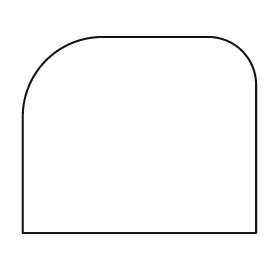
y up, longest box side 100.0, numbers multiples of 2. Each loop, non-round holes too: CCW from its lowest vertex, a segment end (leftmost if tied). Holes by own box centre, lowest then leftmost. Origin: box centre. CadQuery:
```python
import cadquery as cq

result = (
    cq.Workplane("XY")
    .moveTo(-50.0, -42.0)
    .lineTo(50.0, -42.0)
    .lineTo(50.0, 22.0)
    .threePointArc((44.0, 36.0), (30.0, 42.0))
    .lineTo(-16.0, 42.0)
    .threePointArc((-40.0, 32.0), (-50.0, 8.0))
    .close()
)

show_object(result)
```